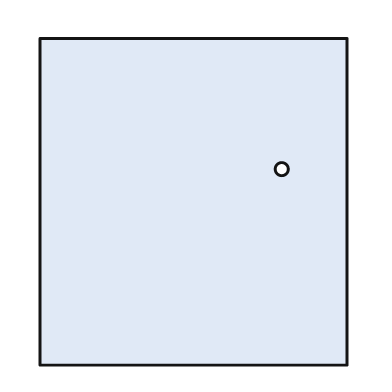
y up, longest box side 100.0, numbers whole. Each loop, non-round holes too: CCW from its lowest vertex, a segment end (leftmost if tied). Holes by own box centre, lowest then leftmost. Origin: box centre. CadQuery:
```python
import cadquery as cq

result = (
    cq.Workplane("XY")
    .moveTo(-47.0, -50.0)
    .lineTo(47.0, -50.0)
    .lineTo(47.0, 50.0)
    .lineTo(-47.0, 50.0)
    .close()
    .moveTo(27.0, 10.0)
    .circle(2.0)
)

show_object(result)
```